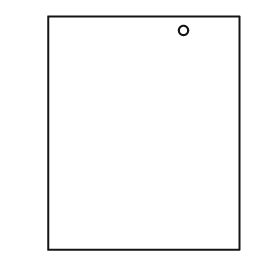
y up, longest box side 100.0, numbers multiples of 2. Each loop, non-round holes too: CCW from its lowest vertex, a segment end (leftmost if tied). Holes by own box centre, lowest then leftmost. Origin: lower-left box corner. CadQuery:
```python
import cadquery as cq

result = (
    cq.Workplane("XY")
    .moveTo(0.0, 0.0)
    .lineTo(82.0, 0.0)
    .lineTo(82.0, 100.0)
    .lineTo(0.0, 100.0)
    .close()
    .moveTo(58.0, 94.0)
    .circle(2.0)
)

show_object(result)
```